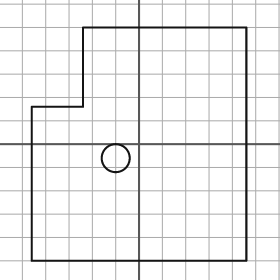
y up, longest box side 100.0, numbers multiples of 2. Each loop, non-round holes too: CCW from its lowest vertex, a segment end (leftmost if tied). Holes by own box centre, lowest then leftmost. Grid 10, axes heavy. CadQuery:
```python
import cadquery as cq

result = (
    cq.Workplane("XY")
    .moveTo(-46.0, -50.0)
    .lineTo(46.0, -50.0)
    .lineTo(46.0, 50.0)
    .lineTo(-24.0, 50.0)
    .lineTo(-24.0, 16.0)
    .lineTo(-46.0, 16.0)
    .close()
    .moveTo(-10.0, -6.0)
    .circle(6.0)
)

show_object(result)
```